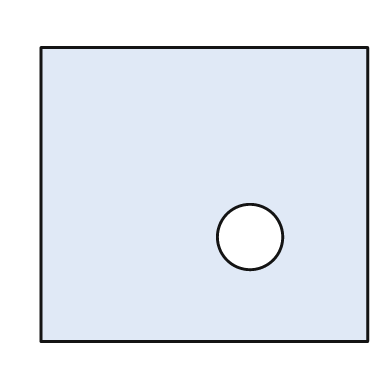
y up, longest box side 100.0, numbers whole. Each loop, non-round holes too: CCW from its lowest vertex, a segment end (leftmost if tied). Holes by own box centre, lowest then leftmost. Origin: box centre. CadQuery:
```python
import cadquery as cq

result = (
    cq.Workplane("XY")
    .moveTo(-50.0, -45.0)
    .lineTo(50.0, -45.0)
    .lineTo(50.0, 45.0)
    .lineTo(-50.0, 45.0)
    .close()
    .moveTo(14.0, -13.0)
    .circle(10.0)
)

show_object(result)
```